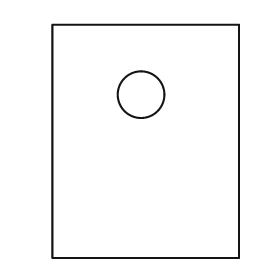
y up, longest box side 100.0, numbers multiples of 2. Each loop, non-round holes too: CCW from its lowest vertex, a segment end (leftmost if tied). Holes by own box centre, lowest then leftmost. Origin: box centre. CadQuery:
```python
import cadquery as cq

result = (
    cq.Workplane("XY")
    .moveTo(-40.0, -50.0)
    .lineTo(40.0, -50.0)
    .lineTo(40.0, 50.0)
    .lineTo(-40.0, 50.0)
    .close()
    .moveTo(-2.0, 20.0)
    .circle(10.0)
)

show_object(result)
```